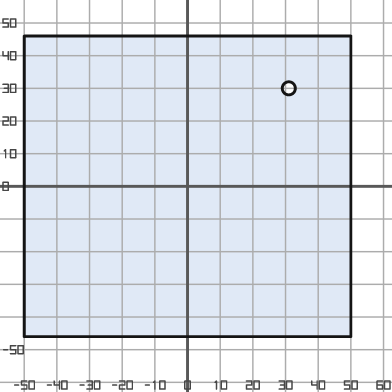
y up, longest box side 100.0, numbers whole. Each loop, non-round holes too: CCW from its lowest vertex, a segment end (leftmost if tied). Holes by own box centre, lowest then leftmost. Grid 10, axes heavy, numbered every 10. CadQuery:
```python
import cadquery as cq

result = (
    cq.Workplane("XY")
    .moveTo(-50.0, -46.0)
    .lineTo(50.0, -46.0)
    .lineTo(50.0, 46.0)
    .lineTo(-50.0, 46.0)
    .close()
    .moveTo(31.0, 30.0)
    .circle(2.0)
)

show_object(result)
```